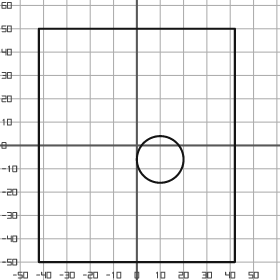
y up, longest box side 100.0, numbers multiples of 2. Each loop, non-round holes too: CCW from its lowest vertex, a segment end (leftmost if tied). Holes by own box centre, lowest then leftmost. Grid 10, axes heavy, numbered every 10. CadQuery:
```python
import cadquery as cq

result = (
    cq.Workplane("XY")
    .moveTo(-42.0, -50.0)
    .lineTo(42.0, -50.0)
    .lineTo(42.0, 50.0)
    .lineTo(-42.0, 50.0)
    .close()
    .moveTo(10.0, -6.0)
    .circle(10.0)
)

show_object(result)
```